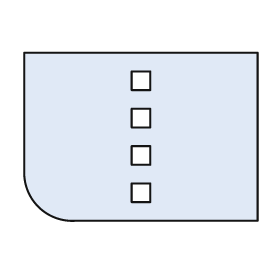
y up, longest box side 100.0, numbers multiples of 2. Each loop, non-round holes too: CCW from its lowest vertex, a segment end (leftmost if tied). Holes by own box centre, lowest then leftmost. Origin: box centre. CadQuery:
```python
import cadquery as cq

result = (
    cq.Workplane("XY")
    .moveTo(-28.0, -36.0)
    .lineTo(50.0, -36.0)
    .lineTo(50.0, 36.0)
    .lineTo(-50.0, 36.0)
    .lineTo(-50.0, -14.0)
    .threePointArc((-44.0, -30.0), (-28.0, -36.0))
    .close()
    .moveTo(-4.0, -28.0)
    .lineTo(4.0, -28.0)
    .lineTo(4.0, -20.0)
    .lineTo(-4.0, -20.0)
    .close()
    .moveTo(-4.0, -12.0)
    .lineTo(4.0, -12.0)
    .lineTo(4.0, -4.0)
    .lineTo(-4.0, -4.0)
    .close()
    .moveTo(-4.0, 4.0)
    .lineTo(4.0, 4.0)
    .lineTo(4.0, 12.0)
    .lineTo(-4.0, 12.0)
    .close()
    .moveTo(-4.0, 20.0)
    .lineTo(4.0, 20.0)
    .lineTo(4.0, 28.0)
    .lineTo(-4.0, 28.0)
    .close()
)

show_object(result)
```